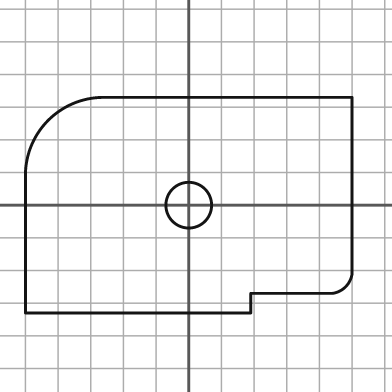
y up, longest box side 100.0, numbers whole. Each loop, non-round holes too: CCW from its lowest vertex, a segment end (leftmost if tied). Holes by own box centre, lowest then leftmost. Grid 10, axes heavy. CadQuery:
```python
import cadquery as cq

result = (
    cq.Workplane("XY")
    .moveTo(-50.0, -33.0)
    .lineTo(19.0, -33.0)
    .lineTo(19.0, -27.0)
    .lineTo(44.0, -27.0)
    .threePointArc((48.0, -25.0), (50.0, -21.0))
    .lineTo(50.0, 33.0)
    .lineTo(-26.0, 33.0)
    .threePointArc((-43.0, 26.0), (-50.0, 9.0))
    .close()
    .moveTo(0.0, 0.0)
    .circle(7.0)
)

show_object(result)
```